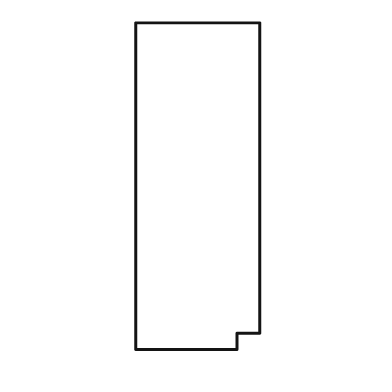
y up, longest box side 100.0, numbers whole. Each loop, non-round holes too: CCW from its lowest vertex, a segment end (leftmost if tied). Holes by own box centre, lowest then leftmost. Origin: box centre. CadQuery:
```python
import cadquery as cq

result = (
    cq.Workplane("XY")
    .moveTo(-19.0, -50.0)
    .lineTo(12.0, -50.0)
    .lineTo(12.0, -45.0)
    .lineTo(19.0, -45.0)
    .lineTo(19.0, 50.0)
    .lineTo(-19.0, 50.0)
    .close()
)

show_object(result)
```